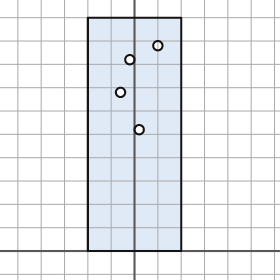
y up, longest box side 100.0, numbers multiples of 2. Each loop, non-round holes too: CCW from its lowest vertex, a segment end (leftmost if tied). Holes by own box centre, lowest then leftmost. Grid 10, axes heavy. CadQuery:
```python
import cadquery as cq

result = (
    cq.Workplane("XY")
    .moveTo(-20.0, 0.0)
    .lineTo(20.0, 0.0)
    .lineTo(20.0, 100.0)
    .lineTo(-20.0, 100.0)
    .close()
    .moveTo(2.0, 52.0)
    .circle(2.0)
    .moveTo(-6.0, 68.0)
    .circle(2.0)
    .moveTo(-2.0, 82.0)
    .circle(2.0)
    .moveTo(10.0, 88.0)
    .circle(2.0)
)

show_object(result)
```